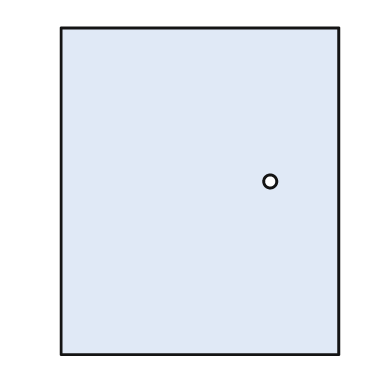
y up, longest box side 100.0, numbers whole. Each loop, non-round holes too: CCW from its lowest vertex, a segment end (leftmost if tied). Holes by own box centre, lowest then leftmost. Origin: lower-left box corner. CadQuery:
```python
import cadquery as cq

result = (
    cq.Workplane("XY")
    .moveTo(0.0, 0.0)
    .lineTo(85.0, 0.0)
    .lineTo(85.0, 100.0)
    .lineTo(0.0, 100.0)
    .close()
    .moveTo(64.0, 53.0)
    .circle(2.0)
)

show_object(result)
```